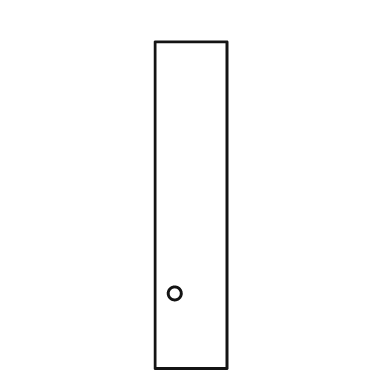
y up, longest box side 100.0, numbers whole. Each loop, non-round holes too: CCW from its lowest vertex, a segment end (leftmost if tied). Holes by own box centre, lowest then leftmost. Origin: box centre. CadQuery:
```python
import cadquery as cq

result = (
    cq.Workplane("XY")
    .moveTo(-11.0, -50.0)
    .lineTo(11.0, -50.0)
    .lineTo(11.0, 50.0)
    .lineTo(-11.0, 50.0)
    .close()
    .moveTo(-5.0, -27.0)
    .circle(2.0)
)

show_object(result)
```